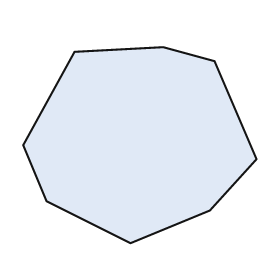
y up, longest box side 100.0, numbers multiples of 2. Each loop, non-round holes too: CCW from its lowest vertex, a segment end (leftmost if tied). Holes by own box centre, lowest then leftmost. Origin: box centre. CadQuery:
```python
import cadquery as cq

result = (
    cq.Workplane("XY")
    .moveTo(-4.0, -42.0)
    .lineTo(30.0, -28.0)
    .lineTo(50.0, -6.0)
    .lineTo(32.0, 36.0)
    .lineTo(10.0, 42.0)
    .lineTo(-28.0, 40.0)
    .lineTo(-50.0, 0.0)
    .lineTo(-40.0, -24.0)
    .close()
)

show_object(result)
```